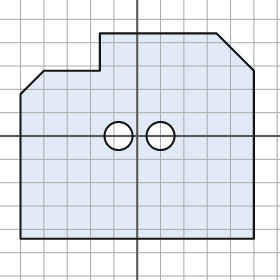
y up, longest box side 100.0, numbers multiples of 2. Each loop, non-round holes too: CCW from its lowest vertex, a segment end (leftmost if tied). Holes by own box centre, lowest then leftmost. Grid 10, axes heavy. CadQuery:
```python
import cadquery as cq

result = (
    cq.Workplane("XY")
    .moveTo(-50.0, -44.0)
    .lineTo(50.0, -44.0)
    .lineTo(50.0, 28.0)
    .lineTo(34.0, 44.0)
    .lineTo(-16.0, 44.0)
    .lineTo(-16.0, 28.0)
    .lineTo(-40.0, 28.0)
    .lineTo(-50.0, 18.0)
    .close()
    .moveTo(-8.0, 0.0)
    .circle(6.0)
    .moveTo(10.0, 0.0)
    .circle(6.0)
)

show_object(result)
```